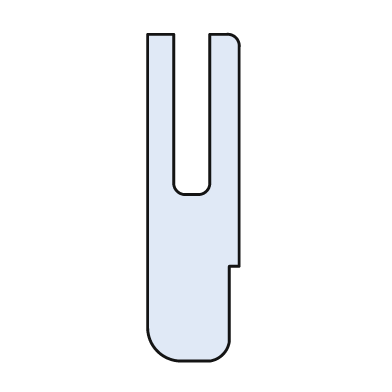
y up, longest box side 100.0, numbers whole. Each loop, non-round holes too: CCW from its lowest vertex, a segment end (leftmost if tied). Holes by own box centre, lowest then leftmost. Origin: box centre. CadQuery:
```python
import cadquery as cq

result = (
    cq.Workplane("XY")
    .moveTo(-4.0, -50.0)
    .lineTo(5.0, -50.0)
    .threePointArc((9.0, -48.0), (11.0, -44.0))
    .lineTo(11.0, -21.0)
    .lineTo(14.0, -21.0)
    .lineTo(14.0, 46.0)
    .threePointArc((13.0, 49.0), (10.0, 50.0))
    .lineTo(5.0, 50.0)
    .lineTo(5.0, 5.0)
    .threePointArc((4.0, 2.0), (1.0, 1.0))
    .lineTo(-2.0, 1.0)
    .threePointArc((-5.0, 2.0), (-6.0, 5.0))
    .lineTo(-6.0, 50.0)
    .lineTo(-14.0, 50.0)
    .lineTo(-14.0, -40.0)
    .threePointArc((-11.0, -47.0), (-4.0, -50.0))
    .close()
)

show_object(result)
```